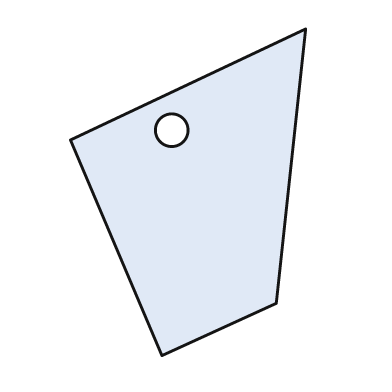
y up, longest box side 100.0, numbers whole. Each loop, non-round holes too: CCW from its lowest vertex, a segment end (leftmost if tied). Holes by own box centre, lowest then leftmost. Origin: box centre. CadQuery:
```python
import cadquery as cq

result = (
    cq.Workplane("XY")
    .moveTo(-8.0, -50.0)
    .lineTo(27.0, -34.0)
    .lineTo(36.0, 50.0)
    .lineTo(-36.0, 16.0)
    .close()
    .moveTo(-5.0, 19.0)
    .circle(5.0)
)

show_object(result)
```